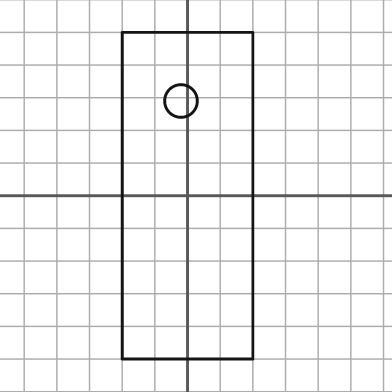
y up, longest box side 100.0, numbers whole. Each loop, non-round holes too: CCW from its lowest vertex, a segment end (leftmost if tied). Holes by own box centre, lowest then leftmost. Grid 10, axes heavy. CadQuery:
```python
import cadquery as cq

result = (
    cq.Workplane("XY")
    .moveTo(-20.0, -50.0)
    .lineTo(20.0, -50.0)
    .lineTo(20.0, 50.0)
    .lineTo(-20.0, 50.0)
    .close()
    .moveTo(-2.0, 29.0)
    .circle(5.0)
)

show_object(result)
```